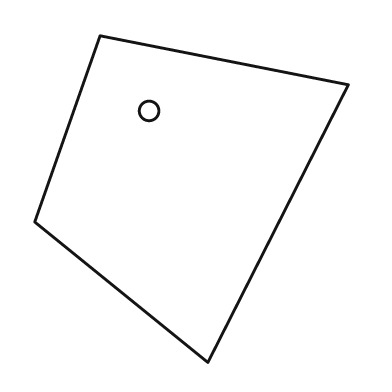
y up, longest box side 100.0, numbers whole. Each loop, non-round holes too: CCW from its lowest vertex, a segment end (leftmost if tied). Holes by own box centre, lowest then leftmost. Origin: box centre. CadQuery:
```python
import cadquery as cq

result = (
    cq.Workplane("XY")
    .moveTo(5.0, -50.0)
    .lineTo(48.0, 35.0)
    .lineTo(-28.0, 50.0)
    .lineTo(-48.0, -7.0)
    .close()
    .moveTo(-13.0, 27.0)
    .circle(3.0)
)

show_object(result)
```